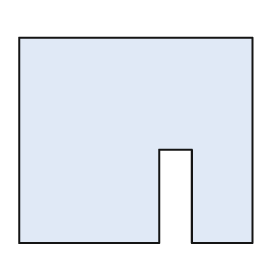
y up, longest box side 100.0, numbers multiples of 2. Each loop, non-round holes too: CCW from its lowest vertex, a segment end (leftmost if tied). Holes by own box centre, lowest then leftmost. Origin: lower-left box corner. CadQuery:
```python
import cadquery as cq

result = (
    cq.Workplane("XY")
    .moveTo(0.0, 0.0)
    .lineTo(60.0, 0.0)
    .lineTo(60.0, 40.0)
    .lineTo(74.0, 40.0)
    .lineTo(74.0, 0.0)
    .lineTo(100.0, 0.0)
    .lineTo(100.0, 88.0)
    .lineTo(0.0, 88.0)
    .close()
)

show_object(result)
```